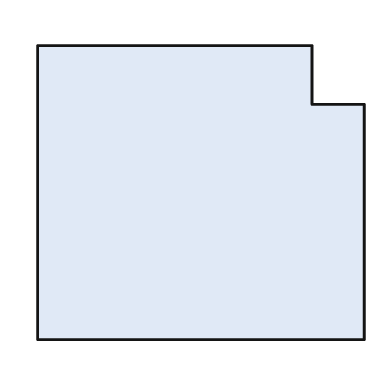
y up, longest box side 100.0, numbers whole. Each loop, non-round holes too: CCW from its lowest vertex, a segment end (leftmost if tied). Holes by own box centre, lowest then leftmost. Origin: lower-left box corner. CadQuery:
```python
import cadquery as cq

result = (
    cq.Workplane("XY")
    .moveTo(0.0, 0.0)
    .lineTo(100.0, 0.0)
    .lineTo(100.0, 72.0)
    .lineTo(84.0, 72.0)
    .lineTo(84.0, 90.0)
    .lineTo(0.0, 90.0)
    .close()
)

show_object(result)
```